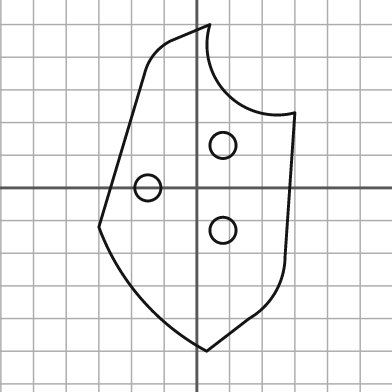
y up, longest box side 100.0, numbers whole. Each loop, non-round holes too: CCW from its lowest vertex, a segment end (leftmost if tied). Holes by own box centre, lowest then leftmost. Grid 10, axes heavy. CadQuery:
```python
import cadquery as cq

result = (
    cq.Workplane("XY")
    .moveTo(3.0, -50.0)
    .lineTo(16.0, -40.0)
    .threePointArc((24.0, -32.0), (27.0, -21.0))
    .lineTo(30.0, 23.0)
    .threePointArc((9.0, 29.0), (4.0, 50.0))
    .lineTo(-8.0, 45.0)
    .threePointArc((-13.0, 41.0), (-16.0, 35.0))
    .lineTo(-30.0, -12.0)
    .threePointArc((-17.0, -34.0), (3.0, -50.0))
    .close()
    .moveTo(8.0, -13.0)
    .circle(4.0)
    .moveTo(-15.0, 0.0)
    .circle(4.0)
    .moveTo(8.0, 13.0)
    .circle(4.0)
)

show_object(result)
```